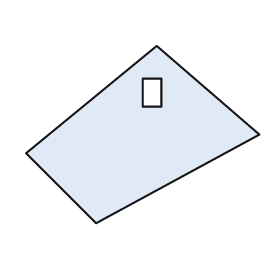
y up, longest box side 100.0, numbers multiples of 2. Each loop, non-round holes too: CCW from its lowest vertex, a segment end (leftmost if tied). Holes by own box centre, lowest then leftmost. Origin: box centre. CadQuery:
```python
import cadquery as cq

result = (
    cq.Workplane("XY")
    .moveTo(-20.0, -38.0)
    .lineTo(50.0, 0.0)
    .lineTo(6.0, 38.0)
    .lineTo(-50.0, -8.0)
    .close()
    .moveTo(0.0, 12.0)
    .lineTo(8.0, 12.0)
    .lineTo(8.0, 24.0)
    .lineTo(0.0, 24.0)
    .close()
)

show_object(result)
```